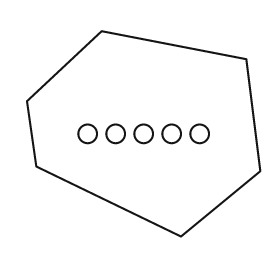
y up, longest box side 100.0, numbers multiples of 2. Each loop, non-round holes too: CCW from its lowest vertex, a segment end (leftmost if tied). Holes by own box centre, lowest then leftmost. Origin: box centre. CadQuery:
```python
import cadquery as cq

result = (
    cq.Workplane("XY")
    .moveTo(16.0, -44.0)
    .lineTo(50.0, -16.0)
    .lineTo(44.0, 32.0)
    .lineTo(-18.0, 44.0)
    .lineTo(-50.0, 14.0)
    .lineTo(-46.0, -14.0)
    .close()
    .moveTo(-24.0, 0.0)
    .circle(4.0)
    .moveTo(-12.0, 0.0)
    .circle(4.0)
    .moveTo(0.0, 0.0)
    .circle(4.0)
    .moveTo(12.0, 0.0)
    .circle(4.0)
    .moveTo(24.0, 0.0)
    .circle(4.0)
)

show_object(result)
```